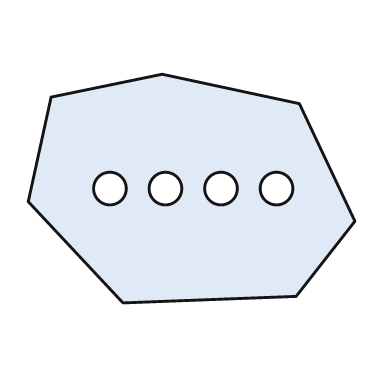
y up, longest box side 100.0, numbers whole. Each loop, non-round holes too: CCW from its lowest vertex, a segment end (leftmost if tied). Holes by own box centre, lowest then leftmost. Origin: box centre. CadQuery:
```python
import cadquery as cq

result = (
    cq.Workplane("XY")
    .moveTo(-21.0, -35.0)
    .lineTo(32.0, -33.0)
    .lineTo(50.0, -10.0)
    .lineTo(33.0, 26.0)
    .lineTo(-9.0, 35.0)
    .lineTo(-43.0, 28.0)
    .lineTo(-50.0, -4.0)
    .close()
    .moveTo(-25.0, 0.0)
    .circle(5.0)
    .moveTo(-8.0, 0.0)
    .circle(5.0)
    .moveTo(9.0, 0.0)
    .circle(5.0)
    .moveTo(26.0, 0.0)
    .circle(5.0)
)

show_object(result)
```